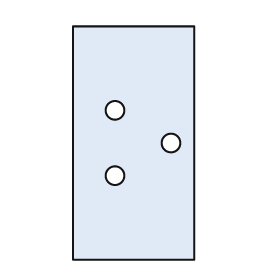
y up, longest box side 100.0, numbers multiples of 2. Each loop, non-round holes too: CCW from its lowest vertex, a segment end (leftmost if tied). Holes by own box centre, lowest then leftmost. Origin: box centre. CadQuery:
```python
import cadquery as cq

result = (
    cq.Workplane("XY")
    .moveTo(-26.0, -50.0)
    .lineTo(26.0, -50.0)
    .lineTo(26.0, 50.0)
    .lineTo(-26.0, 50.0)
    .close()
    .moveTo(-8.0, -14.0)
    .circle(4.0)
    .moveTo(16.0, 0.0)
    .circle(4.0)
    .moveTo(-8.0, 14.0)
    .circle(4.0)
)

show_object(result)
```